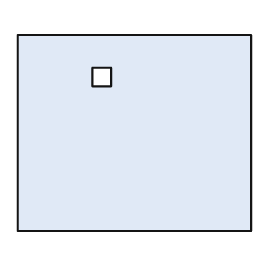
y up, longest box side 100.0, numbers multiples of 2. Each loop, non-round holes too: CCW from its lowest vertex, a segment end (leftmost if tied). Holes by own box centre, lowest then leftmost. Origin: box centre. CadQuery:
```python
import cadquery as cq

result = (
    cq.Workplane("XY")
    .moveTo(-50.0, -42.0)
    .lineTo(50.0, -42.0)
    .lineTo(50.0, 42.0)
    .lineTo(-50.0, 42.0)
    .close()
    .moveTo(-18.0, 20.0)
    .lineTo(-10.0, 20.0)
    .lineTo(-10.0, 28.0)
    .lineTo(-18.0, 28.0)
    .close()
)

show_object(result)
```